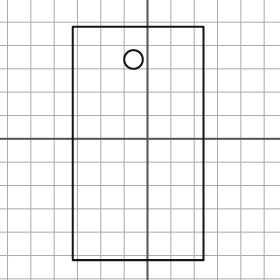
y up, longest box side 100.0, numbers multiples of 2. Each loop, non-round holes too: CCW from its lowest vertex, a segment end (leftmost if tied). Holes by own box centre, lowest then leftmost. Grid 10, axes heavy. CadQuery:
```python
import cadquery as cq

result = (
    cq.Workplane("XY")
    .moveTo(-32.0, -52.0)
    .lineTo(24.0, -52.0)
    .lineTo(24.0, 48.0)
    .lineTo(-32.0, 48.0)
    .close()
    .moveTo(-6.0, 34.0)
    .circle(4.0)
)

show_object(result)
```